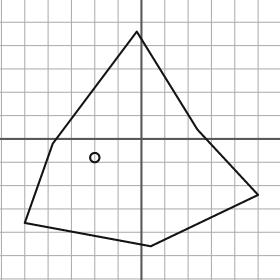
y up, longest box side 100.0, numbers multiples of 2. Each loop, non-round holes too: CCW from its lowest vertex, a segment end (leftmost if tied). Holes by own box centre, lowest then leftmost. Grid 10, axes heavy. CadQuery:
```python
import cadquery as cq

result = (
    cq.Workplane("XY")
    .moveTo(4.0, -46.0)
    .lineTo(50.0, -24.0)
    .lineTo(24.0, 4.0)
    .lineTo(-2.0, 46.0)
    .lineTo(-38.0, -2.0)
    .lineTo(-50.0, -36.0)
    .close()
    .moveTo(-20.0, -8.0)
    .circle(2.0)
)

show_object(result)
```